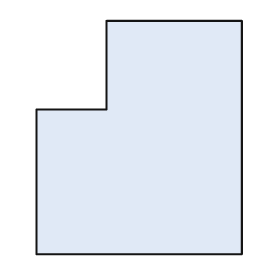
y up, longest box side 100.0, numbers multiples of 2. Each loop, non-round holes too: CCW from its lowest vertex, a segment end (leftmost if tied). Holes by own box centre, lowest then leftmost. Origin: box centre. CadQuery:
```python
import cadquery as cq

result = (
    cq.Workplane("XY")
    .moveTo(-44.0, -50.0)
    .lineTo(44.0, -50.0)
    .lineTo(44.0, 50.0)
    .lineTo(-14.0, 50.0)
    .lineTo(-14.0, 12.0)
    .lineTo(-44.0, 12.0)
    .close()
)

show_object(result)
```